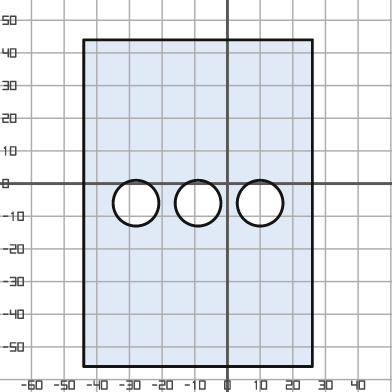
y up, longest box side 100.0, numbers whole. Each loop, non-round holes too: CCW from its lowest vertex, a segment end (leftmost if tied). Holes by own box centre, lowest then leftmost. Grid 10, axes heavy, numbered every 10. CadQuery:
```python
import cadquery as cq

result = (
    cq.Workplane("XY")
    .moveTo(-44.0, -56.0)
    .lineTo(26.0, -56.0)
    .lineTo(26.0, 44.0)
    .lineTo(-44.0, 44.0)
    .close()
    .moveTo(-28.0, -6.0)
    .circle(7.0)
    .moveTo(-9.0, -6.0)
    .circle(7.0)
    .moveTo(10.0, -6.0)
    .circle(7.0)
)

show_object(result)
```